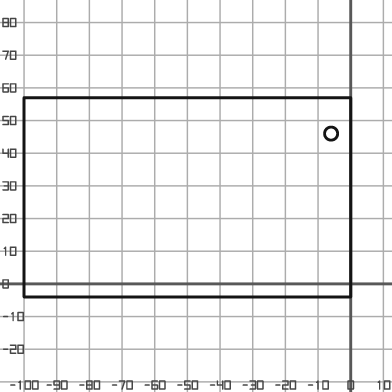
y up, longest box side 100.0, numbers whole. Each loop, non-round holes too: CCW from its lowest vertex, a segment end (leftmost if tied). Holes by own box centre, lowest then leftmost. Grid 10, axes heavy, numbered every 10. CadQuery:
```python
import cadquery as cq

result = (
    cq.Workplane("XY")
    .moveTo(-100.0, -4.0)
    .lineTo(0.0, -4.0)
    .lineTo(0.0, 57.0)
    .lineTo(-100.0, 57.0)
    .close()
    .moveTo(-6.0, 46.0)
    .circle(2.0)
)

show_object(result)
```